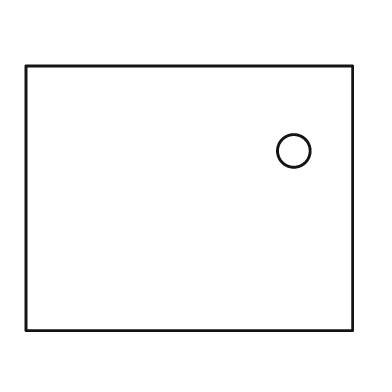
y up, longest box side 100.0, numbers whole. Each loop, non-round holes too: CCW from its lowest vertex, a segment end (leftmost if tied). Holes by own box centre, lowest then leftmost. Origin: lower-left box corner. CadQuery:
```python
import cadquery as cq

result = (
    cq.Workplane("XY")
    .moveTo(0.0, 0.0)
    .lineTo(100.0, 0.0)
    .lineTo(100.0, 81.0)
    .lineTo(0.0, 81.0)
    .close()
    .moveTo(82.0, 55.0)
    .circle(5.0)
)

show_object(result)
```